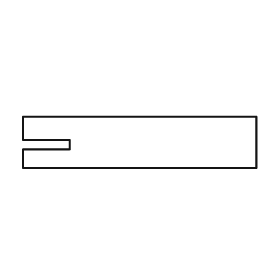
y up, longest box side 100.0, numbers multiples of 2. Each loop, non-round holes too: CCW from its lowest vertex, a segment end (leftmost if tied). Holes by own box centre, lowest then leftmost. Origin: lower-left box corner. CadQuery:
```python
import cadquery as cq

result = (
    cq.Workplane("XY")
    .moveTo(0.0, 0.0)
    .lineTo(100.0, 0.0)
    .lineTo(100.0, 22.0)
    .lineTo(0.0, 22.0)
    .lineTo(0.0, 12.0)
    .lineTo(20.0, 12.0)
    .lineTo(20.0, 8.0)
    .lineTo(0.0, 8.0)
    .close()
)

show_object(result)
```